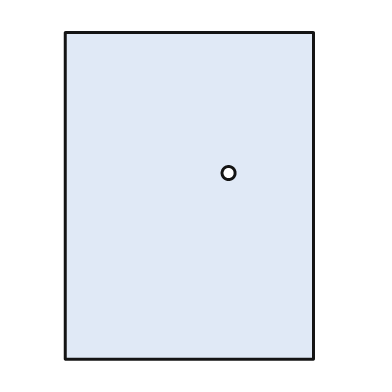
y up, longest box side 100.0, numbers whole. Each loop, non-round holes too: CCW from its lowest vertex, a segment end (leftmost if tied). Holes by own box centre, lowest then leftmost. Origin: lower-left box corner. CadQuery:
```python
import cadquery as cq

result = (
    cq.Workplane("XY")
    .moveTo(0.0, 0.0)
    .lineTo(76.0, 0.0)
    .lineTo(76.0, 100.0)
    .lineTo(0.0, 100.0)
    .close()
    .moveTo(50.0, 57.0)
    .circle(2.0)
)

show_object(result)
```